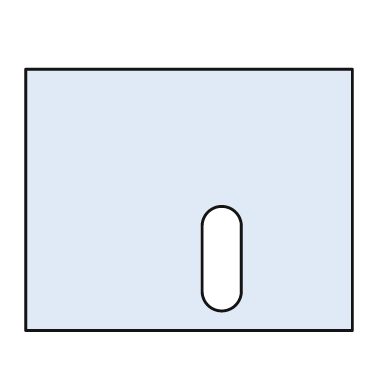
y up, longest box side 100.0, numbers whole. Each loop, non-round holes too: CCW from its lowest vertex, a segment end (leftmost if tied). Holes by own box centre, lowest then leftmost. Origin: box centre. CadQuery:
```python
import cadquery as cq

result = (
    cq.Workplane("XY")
    .moveTo(-50.0, -40.0)
    .lineTo(50.0, -40.0)
    .lineTo(50.0, 40.0)
    .lineTo(-50.0, 40.0)
    .close()
    .moveTo(4.0, -28.0)
    .threePointArc((10.0, -34.0), (16.0, -28.0))
    .lineTo(16.0, -8.0)
    .threePointArc((10.0, -2.0), (4.0, -8.0))
    .close()
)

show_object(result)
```